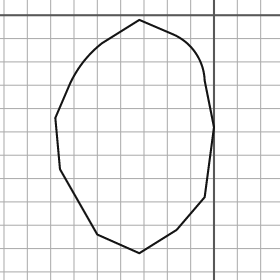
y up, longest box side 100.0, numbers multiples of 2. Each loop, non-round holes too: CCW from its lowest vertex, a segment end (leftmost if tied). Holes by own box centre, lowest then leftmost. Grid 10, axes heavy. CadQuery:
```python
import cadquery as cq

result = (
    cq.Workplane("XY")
    .moveTo(-32.0, -102.0)
    .lineTo(-16.0, -92.0)
    .lineTo(-4.0, -78.0)
    .lineTo(0.0, -48.0)
    .lineTo(-4.0, -28.0)
    .threePointArc((-8.0, -16.0), (-18.0, -8.0))
    .lineTo(-32.0, -2.0)
    .lineTo(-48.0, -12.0)
    .threePointArc((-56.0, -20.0), (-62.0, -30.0))
    .lineTo(-68.0, -44.0)
    .lineTo(-66.0, -66.0)
    .lineTo(-50.0, -94.0)
    .close()
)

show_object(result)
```